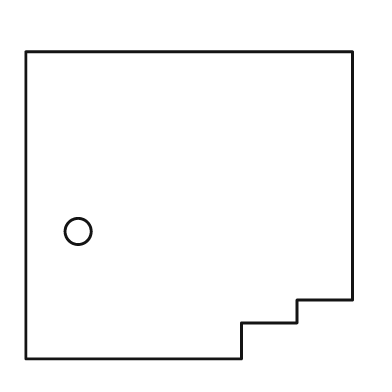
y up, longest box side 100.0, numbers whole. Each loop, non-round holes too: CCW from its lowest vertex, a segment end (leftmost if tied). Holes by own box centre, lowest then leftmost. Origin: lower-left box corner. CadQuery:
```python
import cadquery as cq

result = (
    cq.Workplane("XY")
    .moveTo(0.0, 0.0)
    .lineTo(66.0, 0.0)
    .lineTo(66.0, 11.0)
    .lineTo(83.0, 11.0)
    .lineTo(83.0, 18.0)
    .lineTo(100.0, 18.0)
    .lineTo(100.0, 94.0)
    .lineTo(0.0, 94.0)
    .close()
    .moveTo(16.0, 39.0)
    .circle(4.0)
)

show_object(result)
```